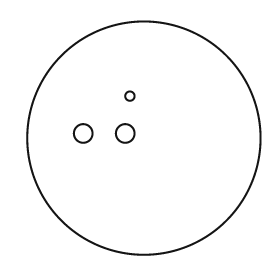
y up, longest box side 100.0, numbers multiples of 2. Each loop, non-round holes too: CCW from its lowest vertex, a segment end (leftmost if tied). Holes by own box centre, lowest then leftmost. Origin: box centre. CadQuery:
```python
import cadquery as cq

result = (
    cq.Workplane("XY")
    .moveTo(0.0, 0.0)
    .circle(50.0)
    .moveTo(-26.0, 2.0)
    .circle(4.0)
    .moveTo(-8.0, 2.0)
    .circle(4.0)
    .moveTo(-6.0, 18.0)
    .circle(2.0)
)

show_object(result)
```